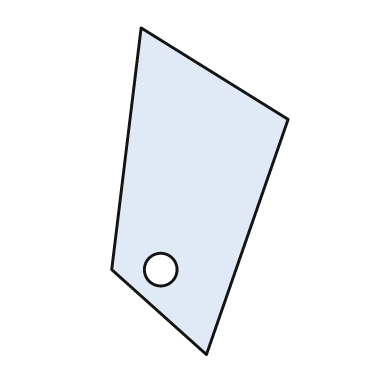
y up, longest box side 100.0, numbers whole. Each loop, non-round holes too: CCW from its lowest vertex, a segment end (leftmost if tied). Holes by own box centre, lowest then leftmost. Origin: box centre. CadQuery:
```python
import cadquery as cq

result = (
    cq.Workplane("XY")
    .moveTo(2.0, -50.0)
    .lineTo(27.0, 22.0)
    .lineTo(-18.0, 50.0)
    .lineTo(-27.0, -24.0)
    .close()
    .moveTo(-12.0, -24.0)
    .circle(5.0)
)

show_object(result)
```